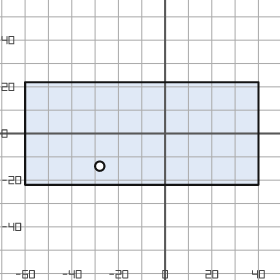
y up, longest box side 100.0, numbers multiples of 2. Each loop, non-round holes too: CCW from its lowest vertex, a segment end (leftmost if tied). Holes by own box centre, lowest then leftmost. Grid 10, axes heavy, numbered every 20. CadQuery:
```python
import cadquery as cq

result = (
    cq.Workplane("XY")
    .moveTo(-60.0, -22.0)
    .lineTo(40.0, -22.0)
    .lineTo(40.0, 22.0)
    .lineTo(-60.0, 22.0)
    .close()
    .moveTo(-28.0, -14.0)
    .circle(2.0)
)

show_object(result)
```